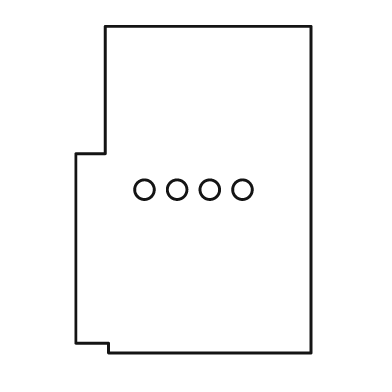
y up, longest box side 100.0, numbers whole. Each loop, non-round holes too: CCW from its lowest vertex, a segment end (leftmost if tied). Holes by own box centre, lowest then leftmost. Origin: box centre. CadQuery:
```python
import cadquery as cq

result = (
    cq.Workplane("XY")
    .moveTo(-26.0, -50.0)
    .lineTo(36.0, -50.0)
    .lineTo(36.0, 50.0)
    .lineTo(-27.0, 50.0)
    .lineTo(-27.0, 11.0)
    .lineTo(-36.0, 11.0)
    .lineTo(-36.0, -47.0)
    .lineTo(-26.0, -47.0)
    .close()
    .moveTo(-15.0, 0.0)
    .circle(3.0)
    .moveTo(-5.0, 0.0)
    .circle(3.0)
    .moveTo(5.0, 0.0)
    .circle(3.0)
    .moveTo(15.0, 0.0)
    .circle(3.0)
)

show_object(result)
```